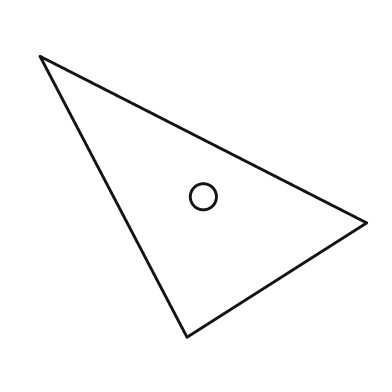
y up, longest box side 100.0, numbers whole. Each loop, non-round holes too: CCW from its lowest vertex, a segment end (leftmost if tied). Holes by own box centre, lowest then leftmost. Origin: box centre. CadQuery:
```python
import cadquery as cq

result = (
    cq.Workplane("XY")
    .moveTo(-5.0, -43.0)
    .lineTo(50.0, -8.0)
    .lineTo(-50.0, 43.0)
    .close()
    .moveTo(0.0, 0.0)
    .circle(4.0)
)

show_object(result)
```